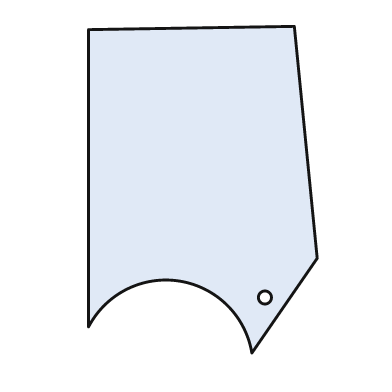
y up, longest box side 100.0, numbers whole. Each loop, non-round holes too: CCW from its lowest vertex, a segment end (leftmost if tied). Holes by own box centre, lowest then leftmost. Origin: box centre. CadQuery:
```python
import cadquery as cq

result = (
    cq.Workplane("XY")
    .moveTo(15.0, -50.0)
    .lineTo(35.0, -21.0)
    .lineTo(28.0, 50.0)
    .lineTo(-35.0, 49.0)
    .lineTo(-35.0, -42.0)
    .threePointArc((-7.0, -28.0), (15.0, -50.0))
    .close()
    .moveTo(19.0, -33.0)
    .circle(2.0)
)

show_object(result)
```